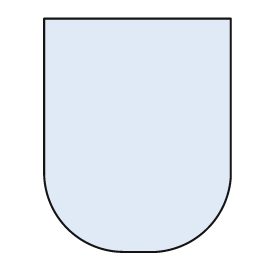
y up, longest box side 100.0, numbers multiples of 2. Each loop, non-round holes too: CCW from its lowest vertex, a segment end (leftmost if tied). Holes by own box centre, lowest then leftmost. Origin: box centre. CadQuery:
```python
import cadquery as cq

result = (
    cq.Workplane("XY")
    .moveTo(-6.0, -50.0)
    .lineTo(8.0, -50.0)
    .threePointArc((30.0, -40.0), (40.0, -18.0))
    .lineTo(40.0, 50.0)
    .lineTo(-40.0, 50.0)
    .lineTo(-40.0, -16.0)
    .threePointArc((-30.0, -40.0), (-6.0, -50.0))
    .close()
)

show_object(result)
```